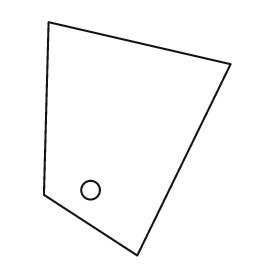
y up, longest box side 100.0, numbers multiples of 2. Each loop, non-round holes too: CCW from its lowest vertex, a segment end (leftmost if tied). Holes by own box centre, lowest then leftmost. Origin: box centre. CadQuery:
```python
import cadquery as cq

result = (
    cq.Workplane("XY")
    .moveTo(0.0, -50.0)
    .lineTo(40.0, 32.0)
    .lineTo(-38.0, 50.0)
    .lineTo(-40.0, -24.0)
    .close()
    .moveTo(-20.0, -22.0)
    .circle(4.0)
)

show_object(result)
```